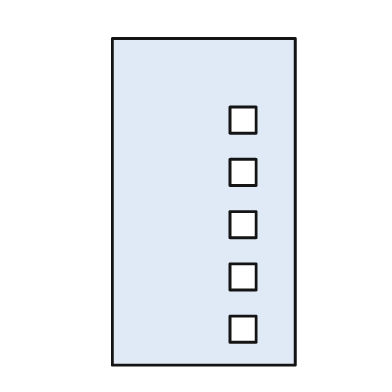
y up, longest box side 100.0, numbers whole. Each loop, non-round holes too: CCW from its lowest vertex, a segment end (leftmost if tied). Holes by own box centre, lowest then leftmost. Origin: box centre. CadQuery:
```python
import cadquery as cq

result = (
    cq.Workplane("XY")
    .moveTo(-28.0, -50.0)
    .lineTo(28.0, -50.0)
    .lineTo(28.0, 50.0)
    .lineTo(-28.0, 50.0)
    .close()
    .moveTo(8.0, -43.0)
    .lineTo(16.0, -43.0)
    .lineTo(16.0, -35.0)
    .lineTo(8.0, -35.0)
    .close()
    .moveTo(8.0, -27.0)
    .lineTo(16.0, -27.0)
    .lineTo(16.0, -19.0)
    .lineTo(8.0, -19.0)
    .close()
    .moveTo(8.0, -11.0)
    .lineTo(16.0, -11.0)
    .lineTo(16.0, -3.0)
    .lineTo(8.0, -3.0)
    .close()
    .moveTo(8.0, 5.0)
    .lineTo(16.0, 5.0)
    .lineTo(16.0, 13.0)
    .lineTo(8.0, 13.0)
    .close()
    .moveTo(8.0, 21.0)
    .lineTo(16.0, 21.0)
    .lineTo(16.0, 29.0)
    .lineTo(8.0, 29.0)
    .close()
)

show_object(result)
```